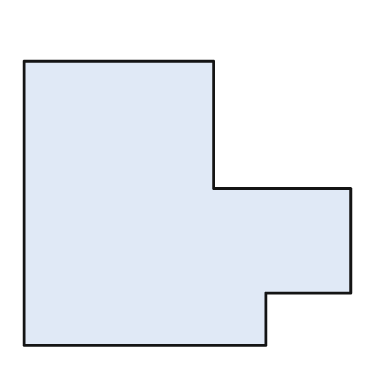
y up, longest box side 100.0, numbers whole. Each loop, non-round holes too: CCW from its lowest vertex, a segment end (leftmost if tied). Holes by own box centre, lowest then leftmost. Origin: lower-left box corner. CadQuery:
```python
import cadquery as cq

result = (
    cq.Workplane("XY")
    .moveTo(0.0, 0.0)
    .lineTo(74.0, 0.0)
    .lineTo(74.0, 16.0)
    .lineTo(100.0, 16.0)
    .lineTo(100.0, 48.0)
    .lineTo(58.0, 48.0)
    .lineTo(58.0, 87.0)
    .lineTo(0.0, 87.0)
    .close()
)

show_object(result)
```